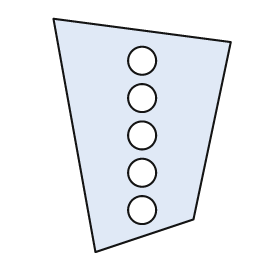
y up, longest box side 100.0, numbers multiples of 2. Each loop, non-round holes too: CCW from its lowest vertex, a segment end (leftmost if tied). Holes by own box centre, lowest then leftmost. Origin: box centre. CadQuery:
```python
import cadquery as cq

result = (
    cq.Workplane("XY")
    .moveTo(-20.0, -50.0)
    .lineTo(22.0, -36.0)
    .lineTo(38.0, 40.0)
    .lineTo(-38.0, 50.0)
    .close()
    .moveTo(0.0, -32.0)
    .circle(6.0)
    .moveTo(0.0, -16.0)
    .circle(6.0)
    .moveTo(0.0, 0.0)
    .circle(6.0)
    .moveTo(0.0, 16.0)
    .circle(6.0)
    .moveTo(0.0, 32.0)
    .circle(6.0)
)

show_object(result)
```